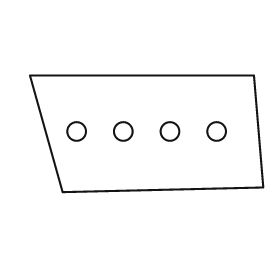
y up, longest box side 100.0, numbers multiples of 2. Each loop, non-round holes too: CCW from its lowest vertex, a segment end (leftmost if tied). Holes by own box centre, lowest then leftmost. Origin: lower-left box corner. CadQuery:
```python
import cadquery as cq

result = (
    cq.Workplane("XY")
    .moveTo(14.0, 0.0)
    .lineTo(100.0, 2.0)
    .lineTo(96.0, 50.0)
    .lineTo(0.0, 50.0)
    .close()
    .moveTo(20.0, 26.0)
    .circle(4.0)
    .moveTo(40.0, 26.0)
    .circle(4.0)
    .moveTo(60.0, 26.0)
    .circle(4.0)
    .moveTo(80.0, 26.0)
    .circle(4.0)
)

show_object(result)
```